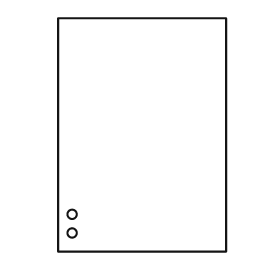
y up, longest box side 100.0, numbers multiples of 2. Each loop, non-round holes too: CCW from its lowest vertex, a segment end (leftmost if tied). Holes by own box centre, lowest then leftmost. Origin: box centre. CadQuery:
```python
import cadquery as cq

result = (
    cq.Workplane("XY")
    .moveTo(-36.0, -50.0)
    .lineTo(36.0, -50.0)
    .lineTo(36.0, 50.0)
    .lineTo(-36.0, 50.0)
    .close()
    .moveTo(-30.0, -42.0)
    .circle(2.0)
    .moveTo(-30.0, -34.0)
    .circle(2.0)
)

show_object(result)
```